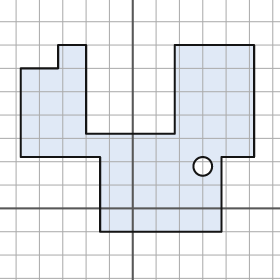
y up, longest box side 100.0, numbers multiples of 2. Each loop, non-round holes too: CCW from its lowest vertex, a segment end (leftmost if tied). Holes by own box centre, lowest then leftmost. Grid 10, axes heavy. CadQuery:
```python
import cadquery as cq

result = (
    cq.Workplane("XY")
    .moveTo(-14.0, -10.0)
    .lineTo(38.0, -10.0)
    .lineTo(38.0, 22.0)
    .lineTo(52.0, 22.0)
    .lineTo(52.0, 70.0)
    .lineTo(18.0, 70.0)
    .lineTo(18.0, 32.0)
    .lineTo(-20.0, 32.0)
    .lineTo(-20.0, 70.0)
    .lineTo(-32.0, 70.0)
    .lineTo(-32.0, 60.0)
    .lineTo(-48.0, 60.0)
    .lineTo(-48.0, 22.0)
    .lineTo(-14.0, 22.0)
    .close()
    .moveTo(30.0, 18.0)
    .circle(4.0)
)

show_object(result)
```